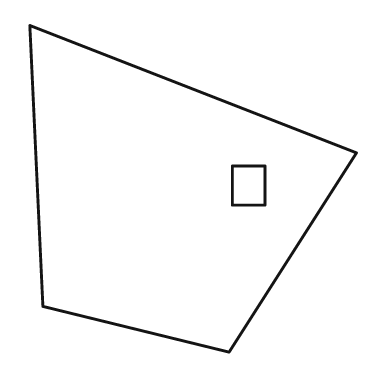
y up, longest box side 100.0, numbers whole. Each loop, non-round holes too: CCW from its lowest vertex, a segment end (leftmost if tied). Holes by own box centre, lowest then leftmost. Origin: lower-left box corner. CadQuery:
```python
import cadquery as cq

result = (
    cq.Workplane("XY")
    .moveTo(61.0, 0.0)
    .lineTo(100.0, 61.0)
    .lineTo(0.0, 100.0)
    .lineTo(4.0, 14.0)
    .close()
    .moveTo(62.0, 45.0)
    .lineTo(72.0, 45.0)
    .lineTo(72.0, 57.0)
    .lineTo(62.0, 57.0)
    .close()
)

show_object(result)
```